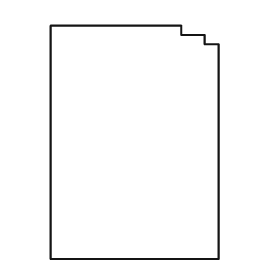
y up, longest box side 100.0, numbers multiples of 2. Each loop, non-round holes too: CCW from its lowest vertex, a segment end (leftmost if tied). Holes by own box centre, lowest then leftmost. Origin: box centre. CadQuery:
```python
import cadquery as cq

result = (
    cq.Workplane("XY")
    .moveTo(-36.0, -50.0)
    .lineTo(36.0, -50.0)
    .lineTo(36.0, 42.0)
    .lineTo(30.0, 42.0)
    .lineTo(30.0, 46.0)
    .lineTo(20.0, 46.0)
    .lineTo(20.0, 50.0)
    .lineTo(-36.0, 50.0)
    .close()
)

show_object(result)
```